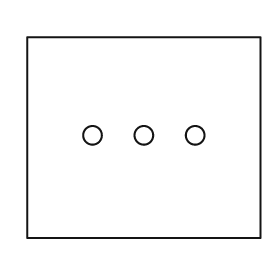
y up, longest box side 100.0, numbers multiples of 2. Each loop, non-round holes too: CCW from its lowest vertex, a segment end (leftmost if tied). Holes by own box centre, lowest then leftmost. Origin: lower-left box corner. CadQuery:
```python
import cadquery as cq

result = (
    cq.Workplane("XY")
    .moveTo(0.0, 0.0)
    .lineTo(100.0, 0.0)
    .lineTo(100.0, 86.0)
    .lineTo(0.0, 86.0)
    .close()
    .moveTo(28.0, 44.0)
    .circle(4.0)
    .moveTo(50.0, 44.0)
    .circle(4.0)
    .moveTo(72.0, 44.0)
    .circle(4.0)
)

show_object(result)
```